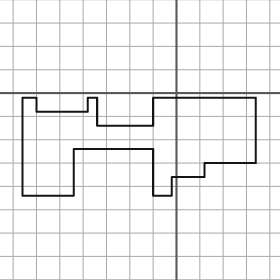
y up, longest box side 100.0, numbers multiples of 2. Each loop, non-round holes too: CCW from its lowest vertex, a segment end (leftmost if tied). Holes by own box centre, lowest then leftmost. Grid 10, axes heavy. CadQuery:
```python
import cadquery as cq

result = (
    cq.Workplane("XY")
    .moveTo(-66.0, -44.0)
    .lineTo(-44.0, -44.0)
    .lineTo(-44.0, -24.0)
    .lineTo(-10.0, -24.0)
    .lineTo(-10.0, -44.0)
    .lineTo(-2.0, -44.0)
    .lineTo(-2.0, -36.0)
    .lineTo(12.0, -36.0)
    .lineTo(12.0, -30.0)
    .lineTo(34.0, -30.0)
    .lineTo(34.0, -2.0)
    .lineTo(-10.0, -2.0)
    .lineTo(-10.0, -14.0)
    .lineTo(-34.0, -14.0)
    .lineTo(-34.0, -2.0)
    .lineTo(-38.0, -2.0)
    .lineTo(-38.0, -8.0)
    .lineTo(-60.0, -8.0)
    .lineTo(-60.0, -2.0)
    .lineTo(-66.0, -2.0)
    .close()
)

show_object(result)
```